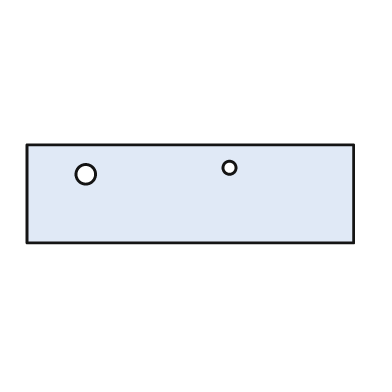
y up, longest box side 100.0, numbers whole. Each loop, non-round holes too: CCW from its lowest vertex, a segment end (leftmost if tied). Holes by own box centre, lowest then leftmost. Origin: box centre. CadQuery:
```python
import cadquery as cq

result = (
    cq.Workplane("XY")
    .moveTo(-50.0, -15.0)
    .lineTo(50.0, -15.0)
    .lineTo(50.0, 15.0)
    .lineTo(-50.0, 15.0)
    .close()
    .moveTo(-32.0, 6.0)
    .circle(3.0)
    .moveTo(12.0, 8.0)
    .circle(2.0)
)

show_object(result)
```